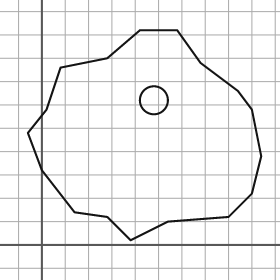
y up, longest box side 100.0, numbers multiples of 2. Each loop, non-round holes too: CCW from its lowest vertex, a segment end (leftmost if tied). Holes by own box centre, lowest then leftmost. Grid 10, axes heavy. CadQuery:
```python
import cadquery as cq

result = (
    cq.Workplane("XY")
    .moveTo(38.0, 2.0)
    .lineTo(54.0, 10.0)
    .lineTo(80.0, 12.0)
    .lineTo(90.0, 22.0)
    .lineTo(94.0, 38.0)
    .lineTo(90.0, 58.0)
    .lineTo(84.0, 66.0)
    .lineTo(68.0, 78.0)
    .lineTo(58.0, 92.0)
    .lineTo(42.0, 92.0)
    .lineTo(28.0, 80.0)
    .lineTo(8.0, 76.0)
    .lineTo(2.0, 58.0)
    .lineTo(-6.0, 48.0)
    .lineTo(0.0, 32.0)
    .lineTo(14.0, 14.0)
    .lineTo(28.0, 12.0)
    .close()
    .moveTo(48.0, 62.0)
    .circle(6.0)
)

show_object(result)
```